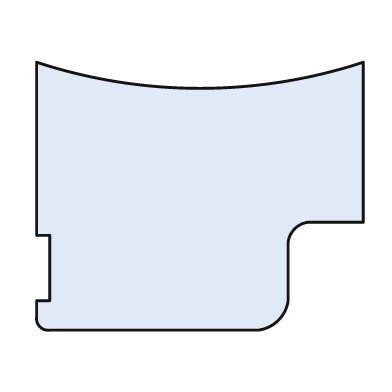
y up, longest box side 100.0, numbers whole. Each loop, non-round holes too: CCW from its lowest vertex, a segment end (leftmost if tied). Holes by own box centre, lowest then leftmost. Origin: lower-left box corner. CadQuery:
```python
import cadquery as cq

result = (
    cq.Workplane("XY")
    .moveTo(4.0, 0.0)
    .lineTo(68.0, 0.0)
    .threePointArc((74.0, 3.0), (77.0, 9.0))
    .lineTo(77.0, 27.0)
    .threePointArc((79.0, 31.0), (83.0, 33.0))
    .lineTo(100.0, 33.0)
    .lineTo(100.0, 82.0)
    .threePointArc((50.0, 74.0), (0.0, 82.0))
    .lineTo(0.0, 29.0)
    .lineTo(4.0, 29.0)
    .lineTo(4.0, 9.0)
    .lineTo(0.0, 9.0)
    .lineTo(0.0, 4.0)
    .threePointArc((1.0, 1.0), (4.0, 0.0))
    .close()
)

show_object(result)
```